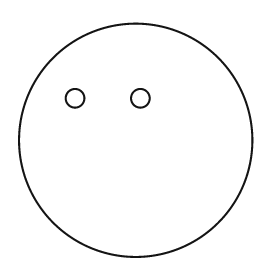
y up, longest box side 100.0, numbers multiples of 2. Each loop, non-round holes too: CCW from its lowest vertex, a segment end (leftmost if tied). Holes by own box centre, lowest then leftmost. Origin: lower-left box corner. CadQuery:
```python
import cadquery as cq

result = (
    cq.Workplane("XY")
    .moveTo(50.0, 50.0)
    .circle(50.0)
    .moveTo(24.0, 68.0)
    .circle(4.0)
    .moveTo(52.0, 68.0)
    .circle(4.0)
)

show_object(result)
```